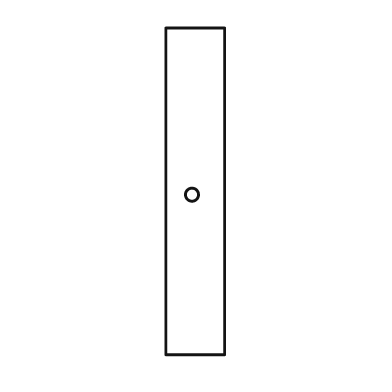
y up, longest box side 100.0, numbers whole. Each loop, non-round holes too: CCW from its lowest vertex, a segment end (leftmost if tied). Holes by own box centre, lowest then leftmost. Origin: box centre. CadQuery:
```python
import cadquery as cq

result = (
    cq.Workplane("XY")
    .moveTo(-9.0, -50.0)
    .lineTo(9.0, -50.0)
    .lineTo(9.0, 50.0)
    .lineTo(-9.0, 50.0)
    .close()
    .moveTo(-1.0, -1.0)
    .circle(2.0)
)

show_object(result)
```